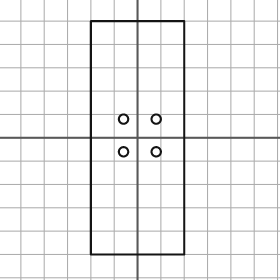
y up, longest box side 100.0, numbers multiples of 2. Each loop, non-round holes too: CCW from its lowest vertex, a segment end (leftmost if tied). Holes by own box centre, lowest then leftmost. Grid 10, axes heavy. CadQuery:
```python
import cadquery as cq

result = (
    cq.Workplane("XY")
    .moveTo(-20.0, -50.0)
    .lineTo(20.0, -50.0)
    .lineTo(20.0, 50.0)
    .lineTo(-20.0, 50.0)
    .close()
    .moveTo(-6.0, -6.0)
    .circle(2.0)
    .moveTo(8.0, -6.0)
    .circle(2.0)
    .moveTo(-6.0, 8.0)
    .circle(2.0)
    .moveTo(8.0, 8.0)
    .circle(2.0)
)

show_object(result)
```